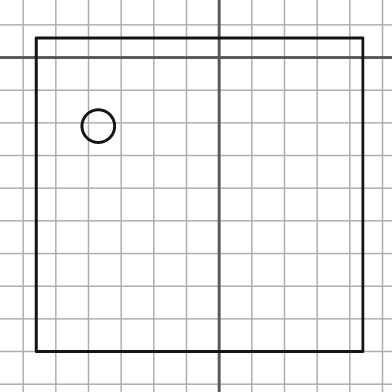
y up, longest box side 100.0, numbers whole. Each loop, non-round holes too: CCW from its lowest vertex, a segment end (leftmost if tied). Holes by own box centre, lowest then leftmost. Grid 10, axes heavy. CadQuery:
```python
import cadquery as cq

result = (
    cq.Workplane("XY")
    .moveTo(-56.0, -90.0)
    .lineTo(44.0, -90.0)
    .lineTo(44.0, 6.0)
    .lineTo(-56.0, 6.0)
    .close()
    .moveTo(-37.0, -21.0)
    .circle(5.0)
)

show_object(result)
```